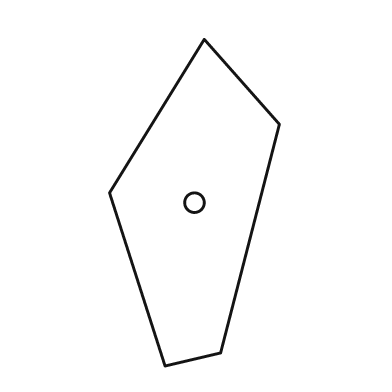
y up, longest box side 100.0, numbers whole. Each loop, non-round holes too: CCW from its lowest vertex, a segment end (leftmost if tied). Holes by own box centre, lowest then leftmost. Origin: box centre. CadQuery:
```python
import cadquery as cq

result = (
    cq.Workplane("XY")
    .moveTo(-9.0, -50.0)
    .lineTo(8.0, -46.0)
    .lineTo(26.0, 24.0)
    .lineTo(3.0, 50.0)
    .lineTo(-26.0, 3.0)
    .close()
    .moveTo(0.0, 0.0)
    .circle(3.0)
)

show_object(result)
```